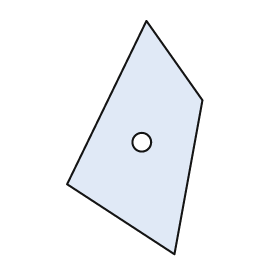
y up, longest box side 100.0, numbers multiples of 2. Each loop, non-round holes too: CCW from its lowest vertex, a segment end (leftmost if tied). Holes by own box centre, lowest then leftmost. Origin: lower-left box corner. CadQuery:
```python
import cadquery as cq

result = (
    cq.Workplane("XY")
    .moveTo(46.0, 0.0)
    .lineTo(58.0, 66.0)
    .lineTo(34.0, 100.0)
    .lineTo(0.0, 30.0)
    .close()
    .moveTo(32.0, 48.0)
    .circle(4.0)
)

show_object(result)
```